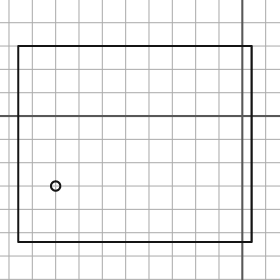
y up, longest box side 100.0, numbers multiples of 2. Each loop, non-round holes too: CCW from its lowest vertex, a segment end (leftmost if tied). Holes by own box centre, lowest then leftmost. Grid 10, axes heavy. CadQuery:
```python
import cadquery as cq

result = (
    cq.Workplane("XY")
    .moveTo(-96.0, -54.0)
    .lineTo(4.0, -54.0)
    .lineTo(4.0, 30.0)
    .lineTo(-96.0, 30.0)
    .close()
    .moveTo(-80.0, -30.0)
    .circle(2.0)
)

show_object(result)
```